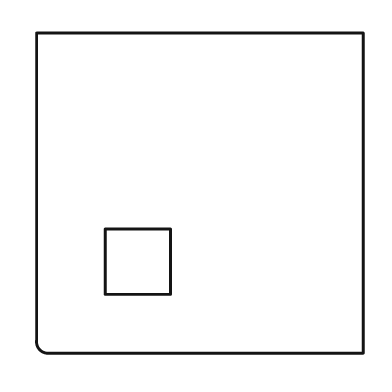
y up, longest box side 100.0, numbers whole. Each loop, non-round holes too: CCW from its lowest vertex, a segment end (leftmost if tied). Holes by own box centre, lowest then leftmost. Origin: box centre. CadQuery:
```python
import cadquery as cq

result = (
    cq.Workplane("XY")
    .moveTo(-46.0, -49.0)
    .lineTo(50.0, -49.0)
    .lineTo(50.0, 49.0)
    .lineTo(-50.0, 49.0)
    .lineTo(-50.0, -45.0)
    .threePointArc((-49.0, -48.0), (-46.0, -49.0))
    .close()
    .moveTo(-29.0, -31.0)
    .lineTo(-9.0, -31.0)
    .lineTo(-9.0, -11.0)
    .lineTo(-29.0, -11.0)
    .close()
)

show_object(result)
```